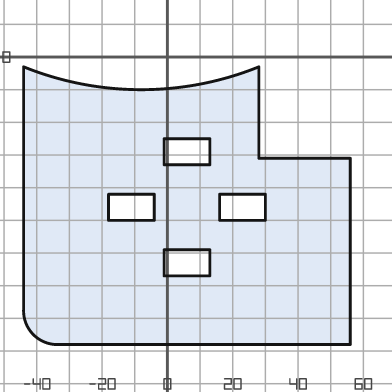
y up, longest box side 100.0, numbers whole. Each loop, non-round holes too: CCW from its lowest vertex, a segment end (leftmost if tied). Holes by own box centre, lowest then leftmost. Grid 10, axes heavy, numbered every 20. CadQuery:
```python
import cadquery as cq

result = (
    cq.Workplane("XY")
    .moveTo(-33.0, -88.0)
    .lineTo(56.0, -88.0)
    .lineTo(56.0, -31.0)
    .lineTo(28.0, -31.0)
    .lineTo(28.0, -3.0)
    .threePointArc((-8.0, -10.0), (-44.0, -3.0))
    .lineTo(-44.0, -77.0)
    .threePointArc((-41.0, -85.0), (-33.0, -88.0))
    .close()
    .moveTo(-1.0, -67.0)
    .lineTo(13.0, -67.0)
    .lineTo(13.0, -59.0)
    .lineTo(-1.0, -59.0)
    .close()
    .moveTo(-18.0, -50.0)
    .lineTo(-4.0, -50.0)
    .lineTo(-4.0, -42.0)
    .lineTo(-18.0, -42.0)
    .close()
    .moveTo(16.0, -50.0)
    .lineTo(30.0, -50.0)
    .lineTo(30.0, -42.0)
    .lineTo(16.0, -42.0)
    .close()
    .moveTo(-1.0, -33.0)
    .lineTo(13.0, -33.0)
    .lineTo(13.0, -25.0)
    .lineTo(-1.0, -25.0)
    .close()
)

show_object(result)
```